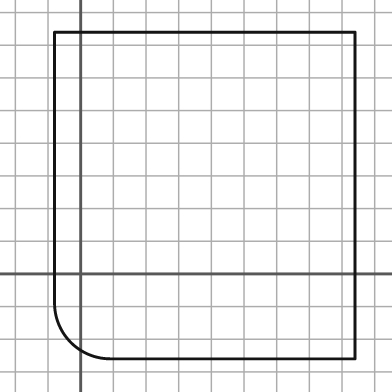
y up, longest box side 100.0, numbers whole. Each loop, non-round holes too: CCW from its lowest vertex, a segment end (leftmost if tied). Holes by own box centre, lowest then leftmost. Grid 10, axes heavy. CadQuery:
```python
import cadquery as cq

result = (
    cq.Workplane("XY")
    .moveTo(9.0, -26.0)
    .lineTo(84.0, -26.0)
    .lineTo(84.0, 74.0)
    .lineTo(-8.0, 74.0)
    .lineTo(-8.0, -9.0)
    .threePointArc((-3.0, -21.0), (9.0, -26.0))
    .close()
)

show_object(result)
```